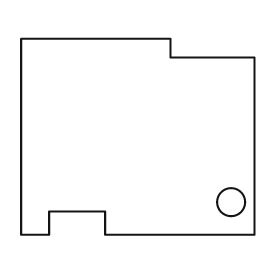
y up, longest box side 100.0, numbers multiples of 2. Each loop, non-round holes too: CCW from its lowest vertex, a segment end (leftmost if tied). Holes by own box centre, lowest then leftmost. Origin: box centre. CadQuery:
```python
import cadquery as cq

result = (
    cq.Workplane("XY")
    .moveTo(-50.0, -42.0)
    .lineTo(-38.0, -42.0)
    .lineTo(-38.0, -32.0)
    .lineTo(-14.0, -32.0)
    .lineTo(-14.0, -42.0)
    .lineTo(50.0, -42.0)
    .lineTo(50.0, 34.0)
    .lineTo(14.0, 34.0)
    .lineTo(14.0, 42.0)
    .lineTo(-50.0, 42.0)
    .close()
    .moveTo(40.0, -28.0)
    .circle(6.0)
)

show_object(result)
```